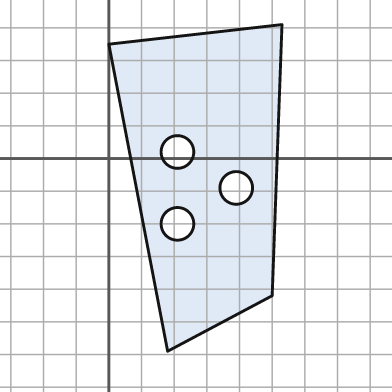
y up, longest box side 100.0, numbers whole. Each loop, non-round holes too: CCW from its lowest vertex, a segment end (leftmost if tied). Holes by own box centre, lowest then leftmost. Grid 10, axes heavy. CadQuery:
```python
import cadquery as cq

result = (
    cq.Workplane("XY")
    .moveTo(18.0, -59.0)
    .lineTo(50.0, -42.0)
    .lineTo(53.0, 41.0)
    .lineTo(0.0, 35.0)
    .close()
    .moveTo(21.0, -20.0)
    .circle(5.0)
    .moveTo(39.0, -9.0)
    .circle(5.0)
    .moveTo(21.0, 2.0)
    .circle(5.0)
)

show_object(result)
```